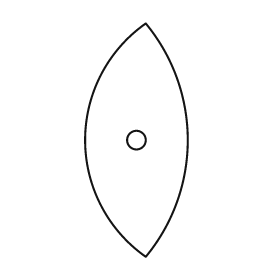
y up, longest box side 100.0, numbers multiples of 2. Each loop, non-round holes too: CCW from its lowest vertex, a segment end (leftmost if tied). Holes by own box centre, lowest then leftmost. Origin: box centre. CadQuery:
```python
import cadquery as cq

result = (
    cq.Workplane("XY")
    .moveTo(4.0, -50.0)
    .threePointArc((22.0, 0.0), (4.0, 50.0))
    .threePointArc((-22.0, 0.0), (4.0, -50.0))
    .close()
    .moveTo(0.0, 0.0)
    .circle(4.0)
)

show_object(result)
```